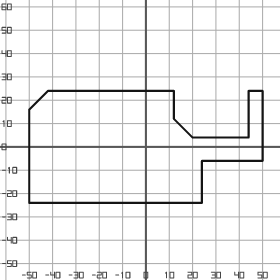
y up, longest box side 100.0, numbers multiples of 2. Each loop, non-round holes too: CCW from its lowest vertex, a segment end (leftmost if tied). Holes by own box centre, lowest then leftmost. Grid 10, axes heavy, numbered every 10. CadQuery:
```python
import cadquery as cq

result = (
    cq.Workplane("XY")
    .moveTo(-50.0, -24.0)
    .lineTo(24.0, -24.0)
    .lineTo(24.0, -6.0)
    .lineTo(50.0, -6.0)
    .lineTo(50.0, 24.0)
    .lineTo(44.0, 24.0)
    .lineTo(44.0, 4.0)
    .lineTo(20.0, 4.0)
    .lineTo(12.0, 12.0)
    .lineTo(12.0, 24.0)
    .lineTo(-42.0, 24.0)
    .lineTo(-50.0, 16.0)
    .close()
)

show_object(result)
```